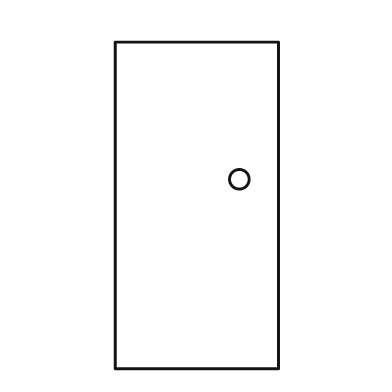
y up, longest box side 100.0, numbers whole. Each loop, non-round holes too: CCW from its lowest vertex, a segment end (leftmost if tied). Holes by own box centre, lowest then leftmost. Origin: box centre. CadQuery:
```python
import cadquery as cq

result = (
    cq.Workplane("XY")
    .moveTo(-25.0, -50.0)
    .lineTo(25.0, -50.0)
    .lineTo(25.0, 50.0)
    .lineTo(-25.0, 50.0)
    .close()
    .moveTo(13.0, 8.0)
    .circle(3.0)
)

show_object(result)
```